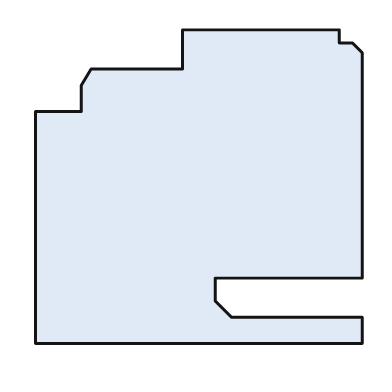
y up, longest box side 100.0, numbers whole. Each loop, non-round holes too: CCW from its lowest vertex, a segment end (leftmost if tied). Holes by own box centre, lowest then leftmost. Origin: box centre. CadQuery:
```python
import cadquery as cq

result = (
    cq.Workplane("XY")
    .moveTo(-50.0, -48.0)
    .lineTo(50.0, -48.0)
    .lineTo(50.0, -40.0)
    .lineTo(10.0, -40.0)
    .lineTo(5.0, -35.0)
    .lineTo(5.0, -28.0)
    .lineTo(50.0, -28.0)
    .lineTo(50.0, 41.0)
    .lineTo(47.0, 44.0)
    .lineTo(43.0, 44.0)
    .lineTo(43.0, 48.0)
    .lineTo(-5.0, 48.0)
    .lineTo(-5.0, 36.0)
    .lineTo(-33.0, 36.0)
    .lineTo(-36.0, 31.0)
    .lineTo(-36.0, 23.0)
    .lineTo(-50.0, 23.0)
    .close()
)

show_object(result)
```